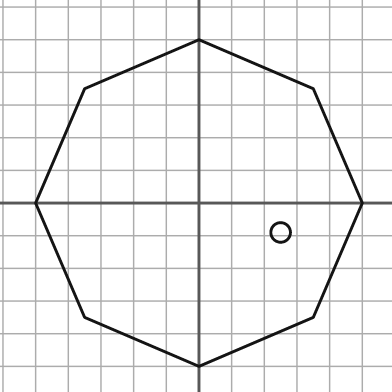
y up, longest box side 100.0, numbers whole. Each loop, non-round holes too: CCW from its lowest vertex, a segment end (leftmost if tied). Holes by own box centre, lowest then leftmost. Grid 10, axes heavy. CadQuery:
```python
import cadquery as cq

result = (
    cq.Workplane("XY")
    .moveTo(0.0, -50.0)
    .lineTo(35.0, -35.0)
    .lineTo(50.0, 0.0)
    .lineTo(35.0, 35.0)
    .lineTo(0.0, 50.0)
    .lineTo(-35.0, 35.0)
    .lineTo(-50.0, 0.0)
    .lineTo(-35.0, -35.0)
    .close()
    .moveTo(25.0, -9.0)
    .circle(3.0)
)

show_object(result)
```